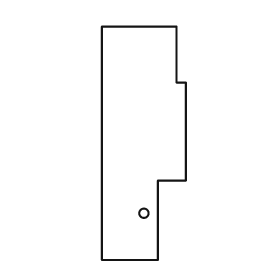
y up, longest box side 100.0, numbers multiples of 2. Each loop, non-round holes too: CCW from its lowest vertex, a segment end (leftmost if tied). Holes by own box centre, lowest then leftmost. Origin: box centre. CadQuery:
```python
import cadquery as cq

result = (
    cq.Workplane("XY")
    .moveTo(-18.0, -50.0)
    .lineTo(6.0, -50.0)
    .lineTo(6.0, -16.0)
    .lineTo(18.0, -16.0)
    .lineTo(18.0, 26.0)
    .lineTo(14.0, 26.0)
    .lineTo(14.0, 50.0)
    .lineTo(-18.0, 50.0)
    .close()
    .moveTo(0.0, -30.0)
    .circle(2.0)
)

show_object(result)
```